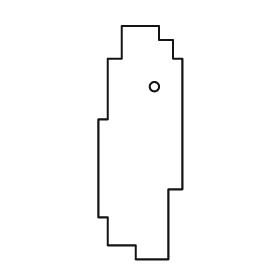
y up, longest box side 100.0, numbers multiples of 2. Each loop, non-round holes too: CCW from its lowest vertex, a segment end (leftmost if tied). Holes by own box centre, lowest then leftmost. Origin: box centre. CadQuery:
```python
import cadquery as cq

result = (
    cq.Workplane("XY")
    .moveTo(-2.0, -50.0)
    .lineTo(12.0, -50.0)
    .lineTo(12.0, -20.0)
    .lineTo(18.0, -20.0)
    .lineTo(18.0, 36.0)
    .lineTo(14.0, 36.0)
    .lineTo(14.0, 44.0)
    .lineTo(8.0, 44.0)
    .lineTo(8.0, 50.0)
    .lineTo(-8.0, 50.0)
    .lineTo(-8.0, 36.0)
    .lineTo(-14.0, 36.0)
    .lineTo(-14.0, 10.0)
    .lineTo(-18.0, 10.0)
    .lineTo(-18.0, -32.0)
    .lineTo(-14.0, -32.0)
    .lineTo(-14.0, -44.0)
    .lineTo(-2.0, -44.0)
    .close()
    .moveTo(6.0, 24.0)
    .circle(2.0)
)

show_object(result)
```